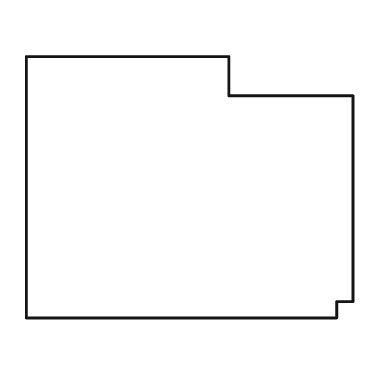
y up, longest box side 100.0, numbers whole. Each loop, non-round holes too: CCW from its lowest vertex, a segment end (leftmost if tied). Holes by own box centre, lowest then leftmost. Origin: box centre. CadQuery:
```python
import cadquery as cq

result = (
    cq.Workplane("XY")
    .moveTo(-50.0, -40.0)
    .lineTo(45.0, -40.0)
    .lineTo(45.0, -35.0)
    .lineTo(50.0, -35.0)
    .lineTo(50.0, 28.0)
    .lineTo(12.0, 28.0)
    .lineTo(12.0, 40.0)
    .lineTo(-50.0, 40.0)
    .close()
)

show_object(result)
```